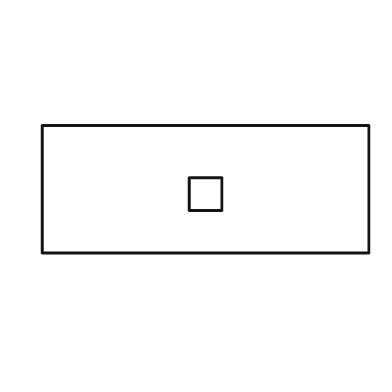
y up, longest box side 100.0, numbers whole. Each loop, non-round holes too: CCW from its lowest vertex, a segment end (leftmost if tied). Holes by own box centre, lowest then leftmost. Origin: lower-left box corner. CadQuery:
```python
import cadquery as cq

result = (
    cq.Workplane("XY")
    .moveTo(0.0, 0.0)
    .lineTo(100.0, 0.0)
    .lineTo(100.0, 39.0)
    .lineTo(0.0, 39.0)
    .close()
    .moveTo(45.0, 13.0)
    .lineTo(55.0, 13.0)
    .lineTo(55.0, 23.0)
    .lineTo(45.0, 23.0)
    .close()
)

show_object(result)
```